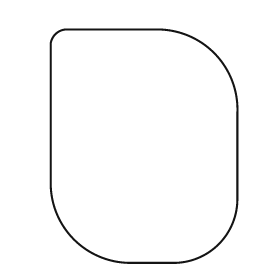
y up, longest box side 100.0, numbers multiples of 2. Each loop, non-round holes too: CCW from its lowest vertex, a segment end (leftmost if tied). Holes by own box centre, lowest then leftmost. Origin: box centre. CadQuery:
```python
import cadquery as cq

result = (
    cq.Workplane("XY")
    .moveTo(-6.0, -50.0)
    .lineTo(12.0, -50.0)
    .threePointArc((32.0, -42.0), (40.0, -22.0))
    .lineTo(40.0, 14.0)
    .threePointArc((30.0, 40.0), (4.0, 50.0))
    .lineTo(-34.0, 50.0)
    .threePointArc((-38.0, 48.0), (-40.0, 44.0))
    .lineTo(-40.0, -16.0)
    .threePointArc((-30.0, -40.0), (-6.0, -50.0))
    .close()
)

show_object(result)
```